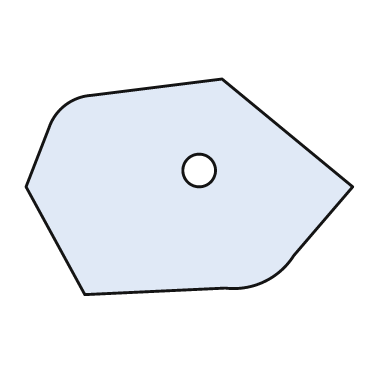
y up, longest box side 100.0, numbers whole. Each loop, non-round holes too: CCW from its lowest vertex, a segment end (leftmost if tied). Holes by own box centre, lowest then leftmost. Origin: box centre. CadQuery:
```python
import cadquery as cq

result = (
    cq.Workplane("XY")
    .moveTo(-32.0, -33.0)
    .lineTo(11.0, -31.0)
    .threePointArc((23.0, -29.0), (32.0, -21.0))
    .lineTo(50.0, 0.0)
    .lineTo(10.0, 33.0)
    .lineTo(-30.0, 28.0)
    .threePointArc((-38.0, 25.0), (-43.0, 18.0))
    .lineTo(-50.0, 0.0)
    .close()
    .moveTo(3.0, 5.0)
    .circle(5.0)
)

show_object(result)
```